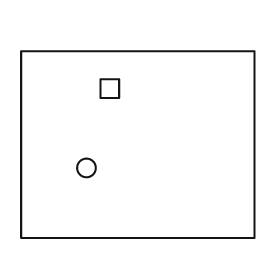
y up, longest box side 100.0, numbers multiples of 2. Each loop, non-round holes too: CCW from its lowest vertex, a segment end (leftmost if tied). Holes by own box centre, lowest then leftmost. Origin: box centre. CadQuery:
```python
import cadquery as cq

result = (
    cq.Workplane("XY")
    .moveTo(-50.0, -40.0)
    .lineTo(50.0, -40.0)
    .lineTo(50.0, 40.0)
    .lineTo(-50.0, 40.0)
    .close()
    .moveTo(-22.0, -10.0)
    .circle(4.0)
    .moveTo(-16.0, 20.0)
    .lineTo(-8.0, 20.0)
    .lineTo(-8.0, 28.0)
    .lineTo(-16.0, 28.0)
    .close()
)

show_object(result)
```